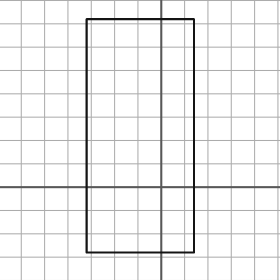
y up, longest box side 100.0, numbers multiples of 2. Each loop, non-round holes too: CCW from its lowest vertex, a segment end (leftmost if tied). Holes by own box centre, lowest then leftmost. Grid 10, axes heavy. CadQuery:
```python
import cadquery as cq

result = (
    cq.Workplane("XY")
    .moveTo(-32.0, -28.0)
    .lineTo(14.0, -28.0)
    .lineTo(14.0, 72.0)
    .lineTo(-32.0, 72.0)
    .close()
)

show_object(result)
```